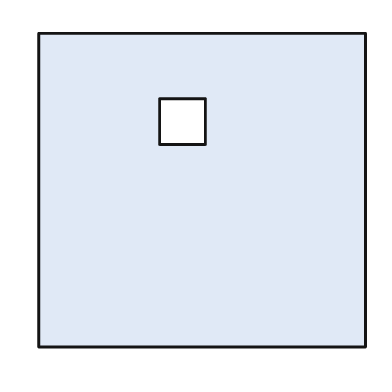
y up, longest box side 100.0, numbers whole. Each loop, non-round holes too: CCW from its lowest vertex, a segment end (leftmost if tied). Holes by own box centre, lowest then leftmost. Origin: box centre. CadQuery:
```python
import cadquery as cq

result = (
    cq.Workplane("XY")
    .moveTo(-50.0, -48.0)
    .lineTo(50.0, -48.0)
    .lineTo(50.0, 48.0)
    .lineTo(-50.0, 48.0)
    .close()
    .moveTo(-13.0, 14.0)
    .lineTo(1.0, 14.0)
    .lineTo(1.0, 28.0)
    .lineTo(-13.0, 28.0)
    .close()
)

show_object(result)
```